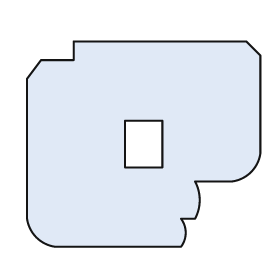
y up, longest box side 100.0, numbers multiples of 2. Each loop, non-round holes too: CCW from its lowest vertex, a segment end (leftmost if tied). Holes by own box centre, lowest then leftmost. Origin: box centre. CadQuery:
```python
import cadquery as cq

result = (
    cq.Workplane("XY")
    .moveTo(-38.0, -44.0)
    .lineTo(16.0, -44.0)
    .threePointArc((18.0, -38.0), (16.0, -32.0))
    .lineTo(22.0, -32.0)
    .threePointArc((24.0, -24.0), (22.0, -16.0))
    .lineTo(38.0, -16.0)
    .threePointArc((46.0, -12.0), (50.0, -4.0))
    .lineTo(50.0, 38.0)
    .lineTo(44.0, 44.0)
    .lineTo(-30.0, 44.0)
    .lineTo(-30.0, 36.0)
    .lineTo(-44.0, 36.0)
    .lineTo(-50.0, 28.0)
    .lineTo(-50.0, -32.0)
    .threePointArc((-46.0, -40.0), (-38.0, -44.0))
    .close()
    .moveTo(-8.0, -10.0)
    .lineTo(8.0, -10.0)
    .lineTo(8.0, 10.0)
    .lineTo(-8.0, 10.0)
    .close()
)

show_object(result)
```